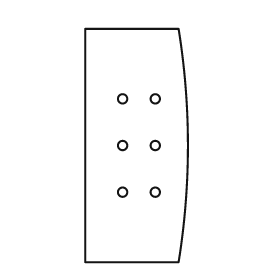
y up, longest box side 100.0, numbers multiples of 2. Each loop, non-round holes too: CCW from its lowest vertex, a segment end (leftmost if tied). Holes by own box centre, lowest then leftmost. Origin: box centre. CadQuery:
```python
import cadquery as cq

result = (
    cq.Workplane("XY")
    .moveTo(-22.0, -50.0)
    .lineTo(18.0, -50.0)
    .threePointArc((22.0, 0.0), (18.0, 50.0))
    .lineTo(-22.0, 50.0)
    .close()
    .moveTo(-6.0, -20.0)
    .circle(2.0)
    .moveTo(8.0, -20.0)
    .circle(2.0)
    .moveTo(-6.0, 0.0)
    .circle(2.0)
    .moveTo(8.0, 0.0)
    .circle(2.0)
    .moveTo(-6.0, 20.0)
    .circle(2.0)
    .moveTo(8.0, 20.0)
    .circle(2.0)
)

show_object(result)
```